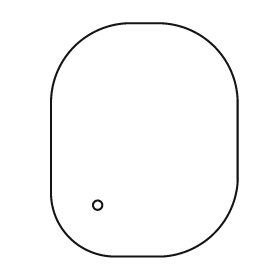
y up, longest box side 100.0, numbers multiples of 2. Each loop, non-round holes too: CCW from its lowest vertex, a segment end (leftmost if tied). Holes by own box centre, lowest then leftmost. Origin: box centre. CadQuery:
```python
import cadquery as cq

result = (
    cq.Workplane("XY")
    .moveTo(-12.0, -50.0)
    .lineTo(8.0, -50.0)
    .threePointArc((30.0, -40.0), (40.0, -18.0))
    .lineTo(40.0, 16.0)
    .threePointArc((30.0, 40.0), (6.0, 50.0))
    .lineTo(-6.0, 50.0)
    .threePointArc((-30.0, 40.0), (-40.0, 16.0))
    .lineTo(-40.0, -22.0)
    .threePointArc((-32.0, -42.0), (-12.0, -50.0))
    .close()
    .moveTo(-20.0, -28.0)
    .circle(2.0)
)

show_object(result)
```